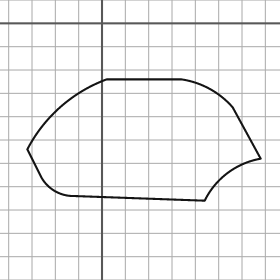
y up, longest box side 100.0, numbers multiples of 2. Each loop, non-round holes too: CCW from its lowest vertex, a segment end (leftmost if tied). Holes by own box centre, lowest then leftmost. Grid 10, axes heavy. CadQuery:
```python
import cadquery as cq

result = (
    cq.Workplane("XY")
    .moveTo(44.0, -76.0)
    .threePointArc((54.0, -64.0), (68.0, -58.0))
    .lineTo(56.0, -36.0)
    .threePointArc((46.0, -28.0), (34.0, -24.0))
    .lineTo(2.0, -24.0)
    .threePointArc((-18.0, -36.0), (-32.0, -54.0))
    .lineTo(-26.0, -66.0)
    .threePointArc((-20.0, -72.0), (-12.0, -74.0))
    .close()
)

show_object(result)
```